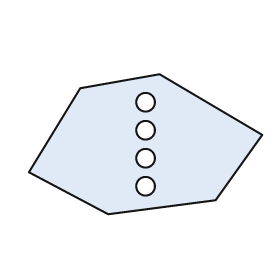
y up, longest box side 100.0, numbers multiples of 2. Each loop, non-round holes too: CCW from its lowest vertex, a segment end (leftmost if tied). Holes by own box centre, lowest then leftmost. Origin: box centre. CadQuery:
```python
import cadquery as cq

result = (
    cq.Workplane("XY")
    .moveTo(-16.0, -30.0)
    .lineTo(30.0, -24.0)
    .lineTo(50.0, 4.0)
    .lineTo(6.0, 30.0)
    .lineTo(-28.0, 24.0)
    .lineTo(-50.0, -12.0)
    .close()
    .moveTo(0.0, -18.0)
    .circle(4.0)
    .moveTo(0.0, -6.0)
    .circle(4.0)
    .moveTo(0.0, 6.0)
    .circle(4.0)
    .moveTo(0.0, 18.0)
    .circle(4.0)
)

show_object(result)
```